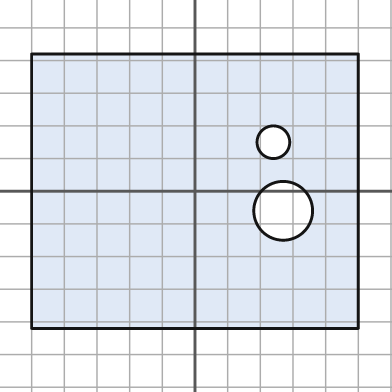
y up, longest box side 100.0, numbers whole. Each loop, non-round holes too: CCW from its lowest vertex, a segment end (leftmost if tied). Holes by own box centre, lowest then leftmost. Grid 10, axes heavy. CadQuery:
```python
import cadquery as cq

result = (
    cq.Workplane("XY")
    .moveTo(-50.0, -42.0)
    .lineTo(50.0, -42.0)
    .lineTo(50.0, 42.0)
    .lineTo(-50.0, 42.0)
    .close()
    .moveTo(27.0, -6.0)
    .circle(9.0)
    .moveTo(24.0, 15.0)
    .circle(5.0)
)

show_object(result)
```